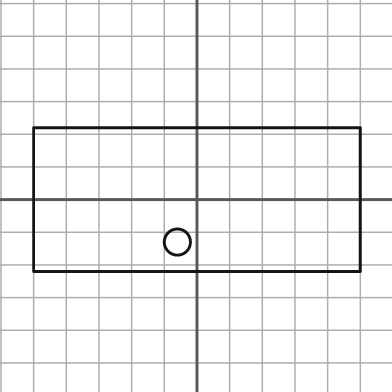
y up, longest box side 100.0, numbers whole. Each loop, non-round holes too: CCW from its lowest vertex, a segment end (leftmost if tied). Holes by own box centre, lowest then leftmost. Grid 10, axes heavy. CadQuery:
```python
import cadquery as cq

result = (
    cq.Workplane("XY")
    .moveTo(-50.0, -22.0)
    .lineTo(50.0, -22.0)
    .lineTo(50.0, 22.0)
    .lineTo(-50.0, 22.0)
    .close()
    .moveTo(-6.0, -13.0)
    .circle(4.0)
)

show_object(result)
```